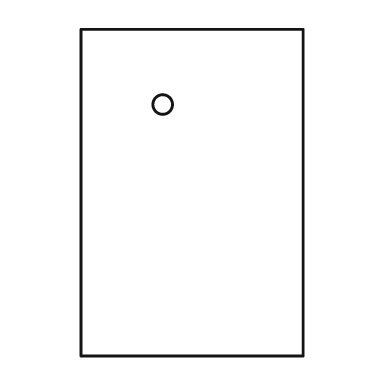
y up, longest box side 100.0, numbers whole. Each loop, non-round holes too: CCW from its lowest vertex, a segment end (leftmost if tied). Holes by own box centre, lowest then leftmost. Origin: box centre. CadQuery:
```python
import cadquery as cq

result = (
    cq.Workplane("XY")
    .moveTo(-34.0, -50.0)
    .lineTo(34.0, -50.0)
    .lineTo(34.0, 50.0)
    .lineTo(-34.0, 50.0)
    .close()
    .moveTo(-9.0, 27.0)
    .circle(3.0)
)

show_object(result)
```